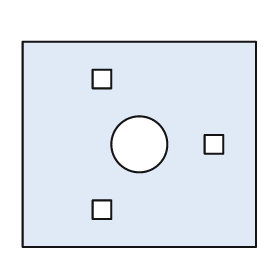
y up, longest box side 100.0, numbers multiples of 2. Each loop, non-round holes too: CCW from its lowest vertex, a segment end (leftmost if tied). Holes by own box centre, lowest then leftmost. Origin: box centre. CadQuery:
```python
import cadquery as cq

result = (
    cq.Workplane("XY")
    .moveTo(-50.0, -44.0)
    .lineTo(50.0, -44.0)
    .lineTo(50.0, 44.0)
    .lineTo(-50.0, 44.0)
    .close()
    .moveTo(-20.0, -32.0)
    .lineTo(-12.0, -32.0)
    .lineTo(-12.0, -24.0)
    .lineTo(-20.0, -24.0)
    .close()
    .moveTo(0.0, 0.0)
    .circle(12.0)
    .moveTo(28.0, -4.0)
    .lineTo(36.0, -4.0)
    .lineTo(36.0, 4.0)
    .lineTo(28.0, 4.0)
    .close()
    .moveTo(-20.0, 24.0)
    .lineTo(-12.0, 24.0)
    .lineTo(-12.0, 32.0)
    .lineTo(-20.0, 32.0)
    .close()
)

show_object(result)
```